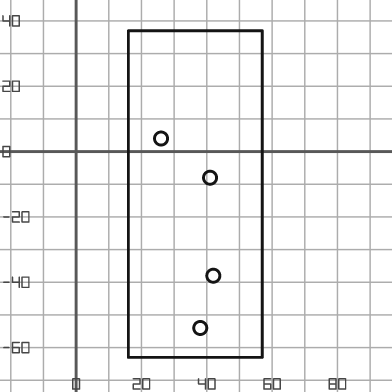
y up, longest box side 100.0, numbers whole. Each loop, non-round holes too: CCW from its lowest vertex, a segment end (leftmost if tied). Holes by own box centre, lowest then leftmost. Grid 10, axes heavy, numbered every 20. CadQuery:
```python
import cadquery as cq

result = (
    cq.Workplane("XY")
    .moveTo(16.0, -63.0)
    .lineTo(57.0, -63.0)
    .lineTo(57.0, 37.0)
    .lineTo(16.0, 37.0)
    .close()
    .moveTo(38.0, -54.0)
    .circle(2.0)
    .moveTo(42.0, -38.0)
    .circle(2.0)
    .moveTo(41.0, -8.0)
    .circle(2.0)
    .moveTo(26.0, 4.0)
    .circle(2.0)
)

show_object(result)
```